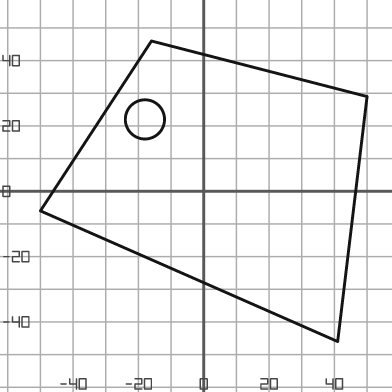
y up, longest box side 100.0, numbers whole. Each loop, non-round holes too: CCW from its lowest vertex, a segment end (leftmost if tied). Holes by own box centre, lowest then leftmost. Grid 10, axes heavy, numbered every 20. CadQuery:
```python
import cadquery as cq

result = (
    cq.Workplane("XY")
    .moveTo(41.0, -46.0)
    .lineTo(50.0, 29.0)
    .lineTo(-16.0, 46.0)
    .lineTo(-50.0, -6.0)
    .close()
    .moveTo(-18.0, 22.0)
    .circle(6.0)
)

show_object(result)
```